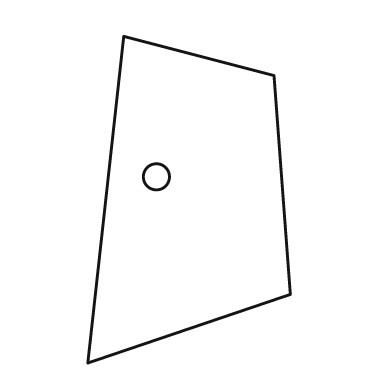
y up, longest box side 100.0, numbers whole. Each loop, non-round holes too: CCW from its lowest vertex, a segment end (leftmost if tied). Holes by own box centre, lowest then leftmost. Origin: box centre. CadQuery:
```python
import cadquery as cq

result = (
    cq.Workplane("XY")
    .moveTo(-31.0, -50.0)
    .lineTo(31.0, -29.0)
    .lineTo(26.0, 38.0)
    .lineTo(-20.0, 50.0)
    .close()
    .moveTo(-10.0, 7.0)
    .circle(4.0)
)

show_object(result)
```